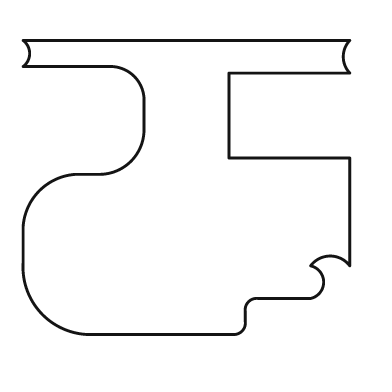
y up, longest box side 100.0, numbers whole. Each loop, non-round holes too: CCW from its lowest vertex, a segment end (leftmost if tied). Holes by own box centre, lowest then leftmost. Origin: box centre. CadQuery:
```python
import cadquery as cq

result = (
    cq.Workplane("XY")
    .moveTo(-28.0, -45.0)
    .lineTo(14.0, -45.0)
    .threePointArc((17.0, -44.0), (18.0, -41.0))
    .lineTo(18.0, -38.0)
    .threePointArc((19.0, -35.0), (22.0, -34.0))
    .lineTo(38.0, -34.0)
    .threePointArc((42.0, -29.0), (38.0, -24.0))
    .threePointArc((44.0, -21.0), (50.0, -24.0))
    .lineTo(50.0, 9.0)
    .lineTo(13.0, 9.0)
    .lineTo(13.0, 35.0)
    .lineTo(50.0, 35.0)
    .threePointArc((48.0, 40.0), (50.0, 45.0))
    .lineTo(-50.0, 45.0)
    .threePointArc((-48.0, 41.0), (-50.0, 37.0))
    .lineTo(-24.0, 37.0)
    .threePointArc((-16.0, 34.0), (-13.0, 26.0))
    .lineTo(-13.0, 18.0)
    .threePointArc((-17.0, 8.0), (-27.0, 4.0))
    .lineTo(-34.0, 4.0)
    .threePointArc((-45.0, -1.0), (-50.0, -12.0))
    .lineTo(-50.0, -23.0)
    .threePointArc((-44.0, -39.0), (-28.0, -45.0))
    .close()
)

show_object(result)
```